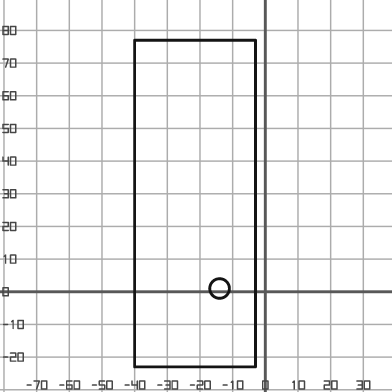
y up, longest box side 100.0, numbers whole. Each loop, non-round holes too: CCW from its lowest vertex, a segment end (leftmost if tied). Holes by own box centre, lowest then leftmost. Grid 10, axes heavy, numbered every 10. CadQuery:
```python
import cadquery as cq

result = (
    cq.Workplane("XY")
    .moveTo(-40.0, -23.0)
    .lineTo(-3.0, -23.0)
    .lineTo(-3.0, 77.0)
    .lineTo(-40.0, 77.0)
    .close()
    .moveTo(-14.0, 1.0)
    .circle(3.0)
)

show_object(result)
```